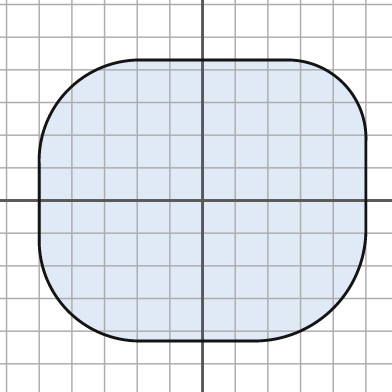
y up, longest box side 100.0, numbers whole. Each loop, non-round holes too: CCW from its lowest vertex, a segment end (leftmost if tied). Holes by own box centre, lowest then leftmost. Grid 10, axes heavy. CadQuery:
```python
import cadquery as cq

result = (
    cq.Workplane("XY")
    .moveTo(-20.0, -43.0)
    .lineTo(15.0, -43.0)
    .threePointArc((40.0, -33.0), (50.0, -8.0))
    .lineTo(50.0, 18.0)
    .threePointArc((43.0, 36.0), (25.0, 43.0))
    .lineTo(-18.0, 43.0)
    .threePointArc((-41.0, 34.0), (-50.0, 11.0))
    .lineTo(-50.0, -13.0)
    .threePointArc((-41.0, -34.0), (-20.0, -43.0))
    .close()
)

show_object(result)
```